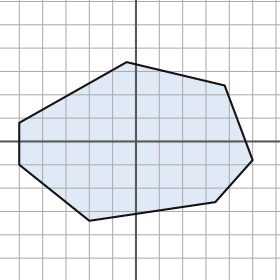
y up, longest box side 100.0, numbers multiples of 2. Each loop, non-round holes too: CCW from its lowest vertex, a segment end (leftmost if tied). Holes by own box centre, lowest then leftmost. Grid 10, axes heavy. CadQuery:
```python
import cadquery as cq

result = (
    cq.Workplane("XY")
    .moveTo(-20.0, -34.0)
    .lineTo(34.0, -26.0)
    .lineTo(50.0, -8.0)
    .lineTo(38.0, 24.0)
    .lineTo(-4.0, 34.0)
    .lineTo(-50.0, 8.0)
    .lineTo(-50.0, -10.0)
    .close()
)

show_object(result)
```